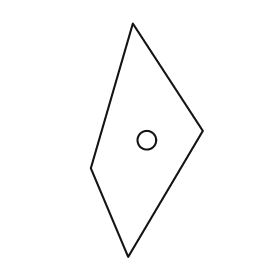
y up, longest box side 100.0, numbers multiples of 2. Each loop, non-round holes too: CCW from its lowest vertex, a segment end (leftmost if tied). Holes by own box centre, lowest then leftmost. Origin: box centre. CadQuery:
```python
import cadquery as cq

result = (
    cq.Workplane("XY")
    .moveTo(-8.0, -50.0)
    .lineTo(24.0, 4.0)
    .lineTo(-6.0, 50.0)
    .lineTo(-24.0, -12.0)
    .close()
    .moveTo(0.0, 0.0)
    .circle(4.0)
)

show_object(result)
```